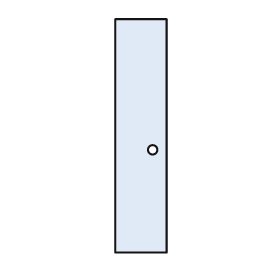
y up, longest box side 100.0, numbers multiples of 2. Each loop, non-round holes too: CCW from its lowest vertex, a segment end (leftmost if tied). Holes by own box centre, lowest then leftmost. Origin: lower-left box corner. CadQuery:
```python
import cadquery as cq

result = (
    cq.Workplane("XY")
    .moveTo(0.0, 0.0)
    .lineTo(22.0, 0.0)
    .lineTo(22.0, 100.0)
    .lineTo(0.0, 100.0)
    .close()
    .moveTo(16.0, 44.0)
    .circle(2.0)
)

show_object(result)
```